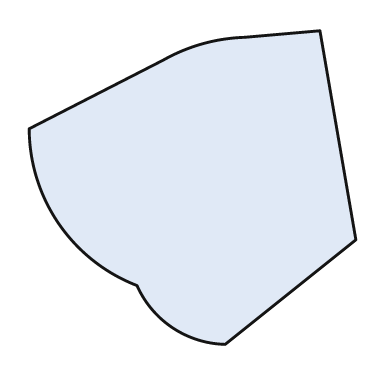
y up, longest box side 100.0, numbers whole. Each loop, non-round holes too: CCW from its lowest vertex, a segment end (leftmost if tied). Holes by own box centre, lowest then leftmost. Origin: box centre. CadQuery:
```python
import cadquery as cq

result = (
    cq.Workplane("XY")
    .moveTo(10.0, -48.0)
    .lineTo(50.0, -16.0)
    .lineTo(39.0, 48.0)
    .lineTo(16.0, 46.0)
    .threePointArc((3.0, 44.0), (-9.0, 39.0))
    .lineTo(-50.0, 18.0)
    .threePointArc((-41.0, -11.0), (-17.0, -30.0))
    .threePointArc((-6.0, -43.0), (10.0, -48.0))
    .close()
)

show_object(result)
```